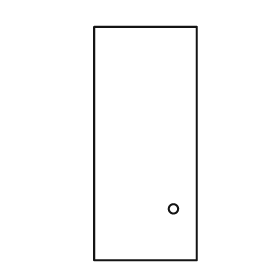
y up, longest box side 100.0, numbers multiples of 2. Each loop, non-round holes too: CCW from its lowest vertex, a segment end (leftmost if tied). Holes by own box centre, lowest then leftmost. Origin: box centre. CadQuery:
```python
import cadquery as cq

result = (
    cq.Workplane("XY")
    .moveTo(-22.0, -50.0)
    .lineTo(22.0, -50.0)
    .lineTo(22.0, 50.0)
    .lineTo(-22.0, 50.0)
    .close()
    .moveTo(12.0, -28.0)
    .circle(2.0)
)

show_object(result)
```